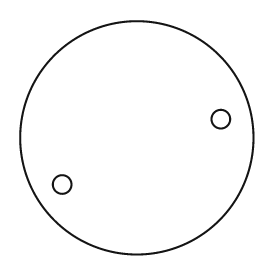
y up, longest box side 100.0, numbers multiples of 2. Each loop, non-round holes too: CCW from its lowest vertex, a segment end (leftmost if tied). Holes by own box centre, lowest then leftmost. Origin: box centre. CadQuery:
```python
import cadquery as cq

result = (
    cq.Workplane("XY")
    .moveTo(0.0, 0.0)
    .circle(50.0)
    .moveTo(-32.0, -20.0)
    .circle(4.0)
    .moveTo(36.0, 8.0)
    .circle(4.0)
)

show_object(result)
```